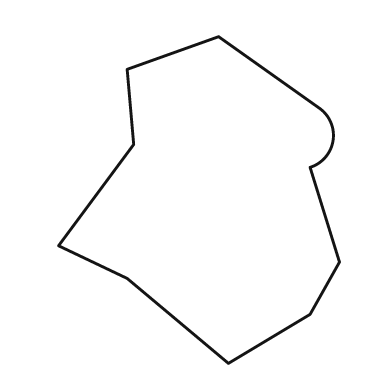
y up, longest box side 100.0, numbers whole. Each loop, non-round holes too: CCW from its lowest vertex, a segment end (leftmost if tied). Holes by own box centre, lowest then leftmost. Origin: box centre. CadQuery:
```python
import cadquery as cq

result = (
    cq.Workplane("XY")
    .moveTo(9.0, -50.0)
    .lineTo(34.0, -35.0)
    .lineTo(43.0, -19.0)
    .lineTo(34.0, 10.0)
    .threePointArc((41.0, 18.0), (37.0, 28.0))
    .lineTo(6.0, 50.0)
    .lineTo(-22.0, 40.0)
    .lineTo(-20.0, 17.0)
    .lineTo(-43.0, -14.0)
    .lineTo(-22.0, -24.0)
    .close()
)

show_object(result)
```